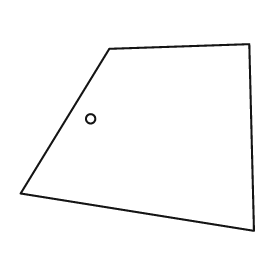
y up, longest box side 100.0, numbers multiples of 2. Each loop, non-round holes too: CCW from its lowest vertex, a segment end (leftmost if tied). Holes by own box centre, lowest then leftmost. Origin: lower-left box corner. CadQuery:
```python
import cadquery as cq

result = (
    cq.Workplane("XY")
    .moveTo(100.0, 0.0)
    .lineTo(98.0, 80.0)
    .lineTo(38.0, 78.0)
    .lineTo(0.0, 16.0)
    .close()
    .moveTo(30.0, 48.0)
    .circle(2.0)
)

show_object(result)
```